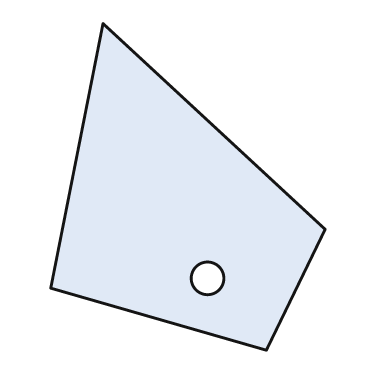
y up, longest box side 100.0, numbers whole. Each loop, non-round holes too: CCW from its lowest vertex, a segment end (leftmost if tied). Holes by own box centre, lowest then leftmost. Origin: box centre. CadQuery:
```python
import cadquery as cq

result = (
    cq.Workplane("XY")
    .moveTo(24.0, -50.0)
    .lineTo(42.0, -13.0)
    .lineTo(-26.0, 50.0)
    .lineTo(-42.0, -31.0)
    .close()
    .moveTo(6.0, -28.0)
    .circle(5.0)
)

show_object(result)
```